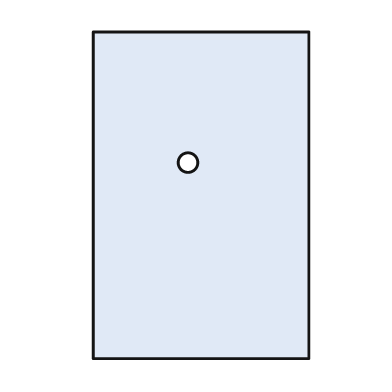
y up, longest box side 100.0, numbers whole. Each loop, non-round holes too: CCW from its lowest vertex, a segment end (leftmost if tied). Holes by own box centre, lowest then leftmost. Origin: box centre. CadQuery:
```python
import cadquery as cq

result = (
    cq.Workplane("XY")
    .moveTo(-33.0, -50.0)
    .lineTo(33.0, -50.0)
    .lineTo(33.0, 50.0)
    .lineTo(-33.0, 50.0)
    .close()
    .moveTo(-4.0, 10.0)
    .circle(3.0)
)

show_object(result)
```